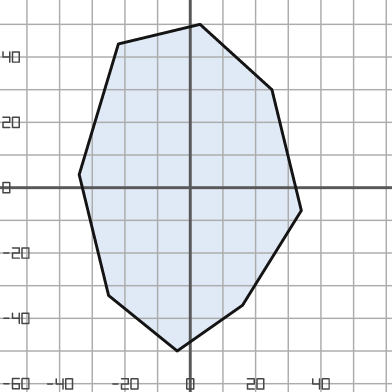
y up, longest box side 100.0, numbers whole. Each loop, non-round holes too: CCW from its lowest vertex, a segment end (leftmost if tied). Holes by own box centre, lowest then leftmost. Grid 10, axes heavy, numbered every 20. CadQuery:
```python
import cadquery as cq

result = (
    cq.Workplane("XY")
    .moveTo(-4.0, -50.0)
    .lineTo(16.0, -36.0)
    .lineTo(34.0, -7.0)
    .lineTo(25.0, 30.0)
    .lineTo(3.0, 50.0)
    .lineTo(-22.0, 44.0)
    .lineTo(-34.0, 4.0)
    .lineTo(-25.0, -33.0)
    .close()
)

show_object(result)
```